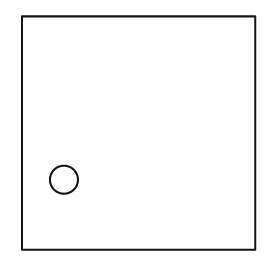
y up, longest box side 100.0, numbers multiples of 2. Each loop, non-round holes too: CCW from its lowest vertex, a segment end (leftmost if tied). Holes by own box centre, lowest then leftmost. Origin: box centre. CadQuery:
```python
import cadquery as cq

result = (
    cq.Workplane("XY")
    .moveTo(-50.0, -50.0)
    .lineTo(50.0, -50.0)
    .lineTo(50.0, 50.0)
    .lineTo(-50.0, 50.0)
    .close()
    .moveTo(-32.0, -20.0)
    .circle(6.0)
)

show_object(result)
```